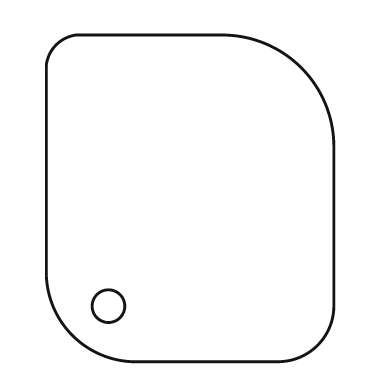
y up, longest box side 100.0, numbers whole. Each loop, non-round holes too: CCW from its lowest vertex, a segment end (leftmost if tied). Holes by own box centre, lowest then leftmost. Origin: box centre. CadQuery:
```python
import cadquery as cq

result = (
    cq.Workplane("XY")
    .moveTo(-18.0, -50.0)
    .lineTo(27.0, -50.0)
    .threePointArc((39.0, -45.0), (44.0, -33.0))
    .lineTo(44.0, 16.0)
    .threePointArc((34.0, 40.0), (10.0, 50.0))
    .lineTo(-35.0, 50.0)
    .threePointArc((-41.0, 47.0), (-44.0, 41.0))
    .lineTo(-44.0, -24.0)
    .threePointArc((-36.0, -42.0), (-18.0, -50.0))
    .close()
    .moveTo(-25.0, -33.0)
    .circle(5.0)
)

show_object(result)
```